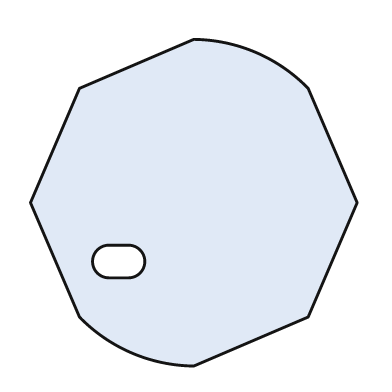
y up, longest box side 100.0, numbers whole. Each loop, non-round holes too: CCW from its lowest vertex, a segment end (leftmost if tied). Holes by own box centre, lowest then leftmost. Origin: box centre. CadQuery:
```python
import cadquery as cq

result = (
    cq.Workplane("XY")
    .moveTo(0.0, -50.0)
    .lineTo(35.0, -35.0)
    .lineTo(50.0, 0.0)
    .lineTo(35.0, 35.0)
    .threePointArc((19.0, 46.0), (0.0, 50.0))
    .lineTo(-35.0, 35.0)
    .lineTo(-50.0, 0.0)
    .lineTo(-35.0, -35.0)
    .threePointArc((-19.0, -46.0), (0.0, -50.0))
    .close()
    .moveTo(-26.0, -23.0)
    .lineTo(-20.0, -23.0)
    .threePointArc((-15.0, -18.0), (-20.0, -13.0))
    .lineTo(-26.0, -13.0)
    .threePointArc((-31.0, -18.0), (-26.0, -23.0))
    .close()
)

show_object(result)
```